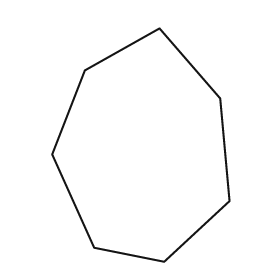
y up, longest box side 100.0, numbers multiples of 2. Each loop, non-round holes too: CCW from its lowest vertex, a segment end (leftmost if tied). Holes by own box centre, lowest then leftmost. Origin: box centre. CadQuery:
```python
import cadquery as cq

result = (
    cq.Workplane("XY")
    .moveTo(10.0, -50.0)
    .lineTo(38.0, -24.0)
    .lineTo(34.0, 20.0)
    .lineTo(8.0, 50.0)
    .lineTo(-24.0, 32.0)
    .lineTo(-38.0, -4.0)
    .lineTo(-20.0, -44.0)
    .close()
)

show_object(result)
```